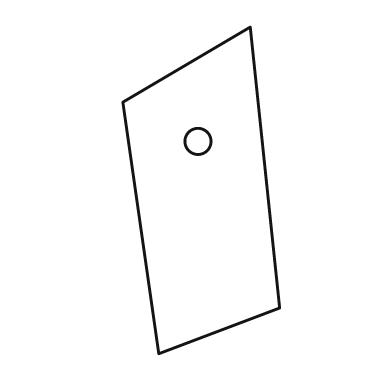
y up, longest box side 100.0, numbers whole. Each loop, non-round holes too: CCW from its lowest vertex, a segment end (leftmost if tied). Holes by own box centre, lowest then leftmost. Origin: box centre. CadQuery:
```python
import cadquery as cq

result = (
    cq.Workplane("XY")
    .moveTo(-13.0, -50.0)
    .lineTo(24.0, -36.0)
    .lineTo(15.0, 50.0)
    .lineTo(-24.0, 27.0)
    .close()
    .moveTo(-1.0, 15.0)
    .circle(4.0)
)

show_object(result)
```